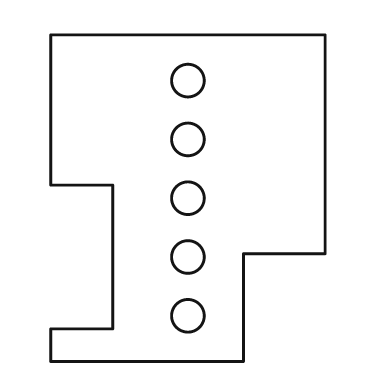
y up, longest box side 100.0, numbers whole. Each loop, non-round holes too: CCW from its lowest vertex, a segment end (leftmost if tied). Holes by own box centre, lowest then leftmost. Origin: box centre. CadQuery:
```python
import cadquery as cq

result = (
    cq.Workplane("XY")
    .moveTo(-42.0, -50.0)
    .lineTo(17.0, -50.0)
    .lineTo(17.0, -17.0)
    .lineTo(42.0, -17.0)
    .lineTo(42.0, 50.0)
    .lineTo(-42.0, 50.0)
    .lineTo(-42.0, 4.0)
    .lineTo(-23.0, 4.0)
    .lineTo(-23.0, -40.0)
    .lineTo(-42.0, -40.0)
    .close()
    .moveTo(0.0, -36.0)
    .circle(5.0)
    .moveTo(0.0, -18.0)
    .circle(5.0)
    .moveTo(0.0, 0.0)
    .circle(5.0)
    .moveTo(0.0, 18.0)
    .circle(5.0)
    .moveTo(0.0, 36.0)
    .circle(5.0)
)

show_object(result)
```